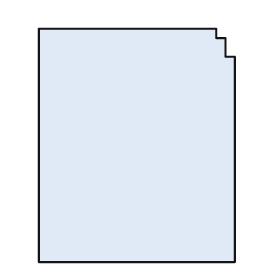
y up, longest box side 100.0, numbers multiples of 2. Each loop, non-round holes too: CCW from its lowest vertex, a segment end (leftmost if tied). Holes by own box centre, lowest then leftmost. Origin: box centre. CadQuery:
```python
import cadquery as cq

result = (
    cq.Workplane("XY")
    .moveTo(-42.0, -50.0)
    .lineTo(42.0, -50.0)
    .lineTo(42.0, 38.0)
    .lineTo(38.0, 38.0)
    .lineTo(38.0, 46.0)
    .lineTo(34.0, 46.0)
    .lineTo(34.0, 50.0)
    .lineTo(-42.0, 50.0)
    .close()
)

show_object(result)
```